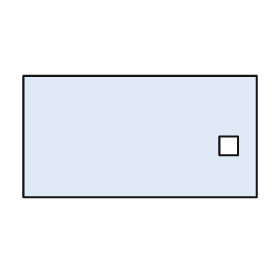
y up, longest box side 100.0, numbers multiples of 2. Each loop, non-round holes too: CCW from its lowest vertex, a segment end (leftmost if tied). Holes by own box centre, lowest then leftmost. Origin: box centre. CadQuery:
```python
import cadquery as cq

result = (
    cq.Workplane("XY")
    .moveTo(-50.0, -26.0)
    .lineTo(50.0, -26.0)
    .lineTo(50.0, 26.0)
    .lineTo(-50.0, 26.0)
    .close()
    .moveTo(34.0, -8.0)
    .lineTo(42.0, -8.0)
    .lineTo(42.0, 0.0)
    .lineTo(34.0, 0.0)
    .close()
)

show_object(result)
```